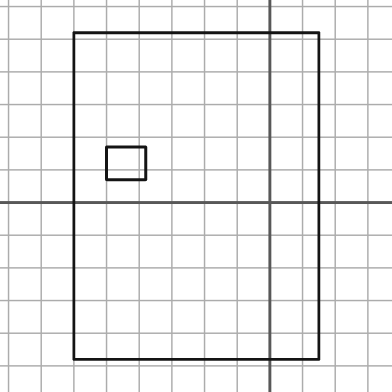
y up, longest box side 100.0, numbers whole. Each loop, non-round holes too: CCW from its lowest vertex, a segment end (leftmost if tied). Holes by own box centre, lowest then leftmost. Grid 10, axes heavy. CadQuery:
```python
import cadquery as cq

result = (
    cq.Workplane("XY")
    .moveTo(-60.0, -48.0)
    .lineTo(15.0, -48.0)
    .lineTo(15.0, 52.0)
    .lineTo(-60.0, 52.0)
    .close()
    .moveTo(-50.0, 7.0)
    .lineTo(-38.0, 7.0)
    .lineTo(-38.0, 17.0)
    .lineTo(-50.0, 17.0)
    .close()
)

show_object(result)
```